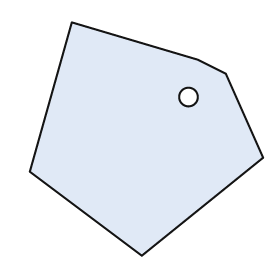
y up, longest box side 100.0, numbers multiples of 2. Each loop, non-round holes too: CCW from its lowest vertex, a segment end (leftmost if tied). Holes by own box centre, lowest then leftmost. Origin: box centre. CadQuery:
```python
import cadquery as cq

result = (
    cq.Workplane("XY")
    .moveTo(-2.0, -50.0)
    .lineTo(50.0, -8.0)
    .lineTo(34.0, 28.0)
    .lineTo(22.0, 34.0)
    .lineTo(-32.0, 50.0)
    .lineTo(-50.0, -14.0)
    .close()
    .moveTo(18.0, 18.0)
    .circle(4.0)
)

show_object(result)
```